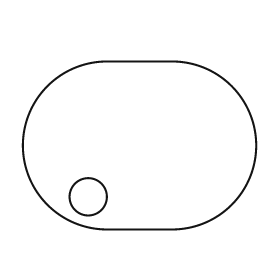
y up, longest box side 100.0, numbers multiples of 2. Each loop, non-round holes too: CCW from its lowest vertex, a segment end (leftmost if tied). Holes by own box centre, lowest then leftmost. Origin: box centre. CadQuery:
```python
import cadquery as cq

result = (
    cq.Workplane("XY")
    .moveTo(-14.0, -36.0)
    .lineTo(14.0, -36.0)
    .threePointArc((50.0, 0.0), (14.0, 36.0))
    .lineTo(-14.0, 36.0)
    .threePointArc((-50.0, 0.0), (-14.0, -36.0))
    .close()
    .moveTo(-22.0, -22.0)
    .circle(8.0)
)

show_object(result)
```